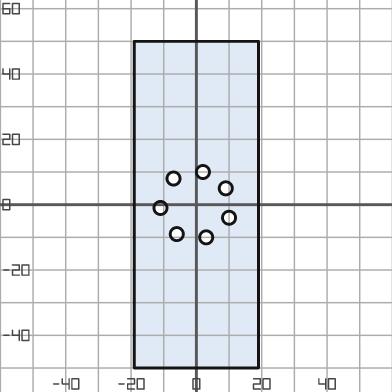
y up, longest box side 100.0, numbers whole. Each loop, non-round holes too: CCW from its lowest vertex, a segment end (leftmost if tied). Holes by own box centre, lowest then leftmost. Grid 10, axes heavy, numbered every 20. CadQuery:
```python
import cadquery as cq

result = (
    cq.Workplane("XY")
    .moveTo(-19.0, -50.0)
    .lineTo(19.0, -50.0)
    .lineTo(19.0, 50.0)
    .lineTo(-19.0, 50.0)
    .close()
    .moveTo(3.0, -10.0)
    .circle(2.0)
    .moveTo(-6.0, -9.0)
    .circle(2.0)
    .moveTo(10.0, -4.0)
    .circle(2.0)
    .moveTo(-11.0, -1.0)
    .circle(2.0)
    .moveTo(9.0, 5.0)
    .circle(2.0)
    .moveTo(-7.0, 8.0)
    .circle(2.0)
    .moveTo(2.0, 10.0)
    .circle(2.0)
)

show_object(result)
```